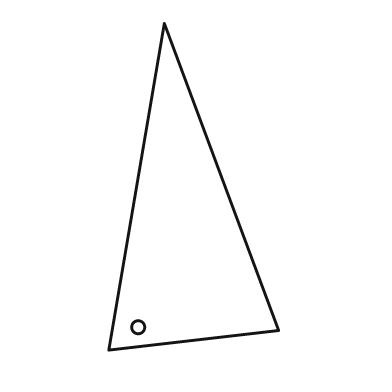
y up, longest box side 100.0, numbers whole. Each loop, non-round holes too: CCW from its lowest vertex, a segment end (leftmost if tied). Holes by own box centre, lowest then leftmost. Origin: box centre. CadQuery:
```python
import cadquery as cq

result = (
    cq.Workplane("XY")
    .moveTo(-26.0, -50.0)
    .lineTo(26.0, -44.0)
    .lineTo(-9.0, 50.0)
    .close()
    .moveTo(-17.0, -43.0)
    .circle(2.0)
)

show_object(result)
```